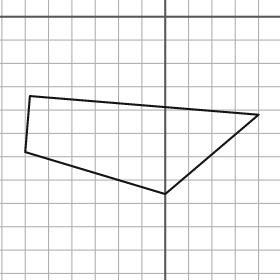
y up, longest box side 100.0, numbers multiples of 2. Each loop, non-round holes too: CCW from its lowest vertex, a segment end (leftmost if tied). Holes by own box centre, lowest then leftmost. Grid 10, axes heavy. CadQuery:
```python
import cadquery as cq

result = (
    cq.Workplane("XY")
    .moveTo(0.0, -76.0)
    .lineTo(40.0, -42.0)
    .lineTo(-58.0, -34.0)
    .lineTo(-60.0, -58.0)
    .close()
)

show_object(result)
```